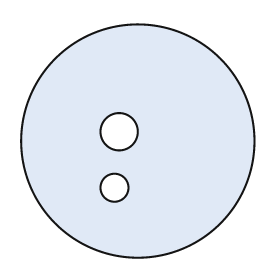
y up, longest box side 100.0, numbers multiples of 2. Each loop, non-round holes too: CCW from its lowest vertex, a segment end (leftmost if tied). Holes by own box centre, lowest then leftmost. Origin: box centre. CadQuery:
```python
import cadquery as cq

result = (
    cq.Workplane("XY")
    .moveTo(0.0, 0.0)
    .circle(50.0)
    .moveTo(-10.0, -20.0)
    .circle(6.0)
    .moveTo(-8.0, 4.0)
    .circle(8.0)
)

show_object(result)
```